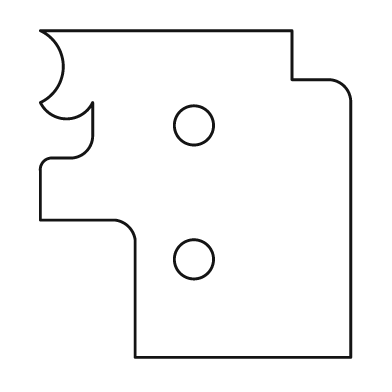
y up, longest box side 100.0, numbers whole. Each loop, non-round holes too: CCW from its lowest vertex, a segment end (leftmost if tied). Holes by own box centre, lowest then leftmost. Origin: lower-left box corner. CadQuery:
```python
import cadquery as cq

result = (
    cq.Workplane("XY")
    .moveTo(29.0, 0.0)
    .lineTo(95.0, 0.0)
    .lineTo(95.0, 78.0)
    .threePointArc((93.0, 83.0), (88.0, 85.0))
    .lineTo(77.0, 85.0)
    .lineTo(77.0, 100.0)
    .lineTo(0.0, 100.0)
    .threePointArc((7.0, 89.0), (0.0, 78.0))
    .threePointArc((8.0, 73.0), (16.0, 78.0))
    .lineTo(16.0, 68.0)
    .threePointArc((14.0, 63.0), (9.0, 61.0))
    .lineTo(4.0, 61.0)
    .threePointArc((1.0, 60.0), (0.0, 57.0))
    .lineTo(0.0, 42.0)
    .lineTo(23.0, 42.0)
    .threePointArc((27.0, 40.0), (29.0, 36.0))
    .close()
    .moveTo(47.0, 30.0)
    .circle(6.0)
    .moveTo(47.0, 71.0)
    .circle(6.0)
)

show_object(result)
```